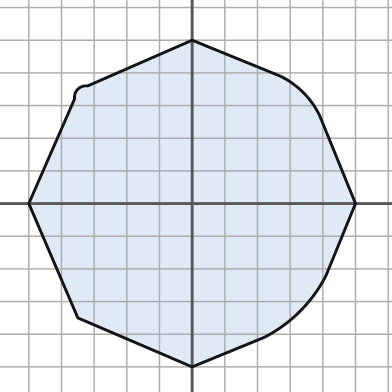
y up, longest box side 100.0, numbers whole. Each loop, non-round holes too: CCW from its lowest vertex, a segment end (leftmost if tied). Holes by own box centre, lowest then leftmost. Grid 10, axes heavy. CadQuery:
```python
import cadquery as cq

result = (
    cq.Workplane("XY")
    .moveTo(0.0, -50.0)
    .lineTo(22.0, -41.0)
    .threePointArc((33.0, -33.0), (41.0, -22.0))
    .lineTo(50.0, 0.0)
    .lineTo(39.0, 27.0)
    .threePointArc((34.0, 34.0), (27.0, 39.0))
    .lineTo(0.0, 50.0)
    .lineTo(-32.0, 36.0)
    .threePointArc((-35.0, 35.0), (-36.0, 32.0))
    .lineTo(-50.0, 0.0)
    .lineTo(-35.0, -35.0)
    .close()
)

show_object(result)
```